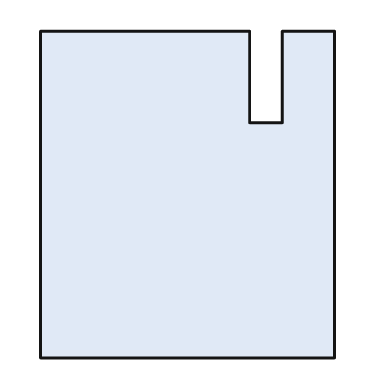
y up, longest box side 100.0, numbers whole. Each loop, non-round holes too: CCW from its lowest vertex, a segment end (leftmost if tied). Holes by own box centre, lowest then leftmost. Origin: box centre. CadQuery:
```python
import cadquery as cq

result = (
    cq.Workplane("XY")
    .moveTo(-45.0, -50.0)
    .lineTo(45.0, -50.0)
    .lineTo(45.0, 50.0)
    .lineTo(29.0, 50.0)
    .lineTo(29.0, 22.0)
    .lineTo(19.0, 22.0)
    .lineTo(19.0, 50.0)
    .lineTo(-45.0, 50.0)
    .close()
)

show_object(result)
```